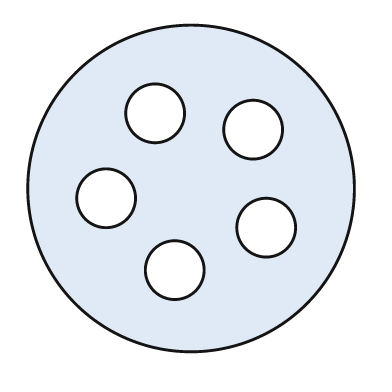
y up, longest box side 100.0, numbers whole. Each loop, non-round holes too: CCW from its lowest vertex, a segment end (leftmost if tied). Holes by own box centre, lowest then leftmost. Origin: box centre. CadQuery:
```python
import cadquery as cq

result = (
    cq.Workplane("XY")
    .moveTo(0.0, 0.0)
    .circle(50.0)
    .moveTo(-5.0, -25.0)
    .circle(9.0)
    .moveTo(23.0, -12.0)
    .circle(9.0)
    .moveTo(-26.0, -3.0)
    .circle(9.0)
    .moveTo(19.0, 18.0)
    .circle(9.0)
    .moveTo(-11.0, 23.0)
    .circle(9.0)
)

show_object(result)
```